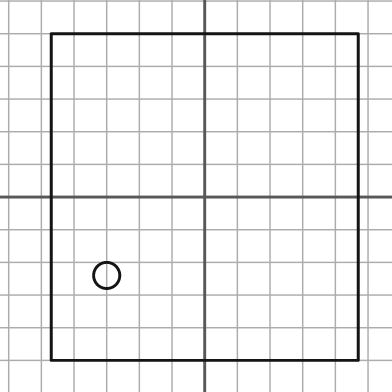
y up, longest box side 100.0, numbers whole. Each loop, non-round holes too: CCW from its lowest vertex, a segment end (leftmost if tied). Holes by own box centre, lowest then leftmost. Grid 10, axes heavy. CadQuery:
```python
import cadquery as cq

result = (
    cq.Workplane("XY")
    .moveTo(-47.0, -50.0)
    .lineTo(47.0, -50.0)
    .lineTo(47.0, 50.0)
    .lineTo(-47.0, 50.0)
    .close()
    .moveTo(-30.0, -24.0)
    .circle(4.0)
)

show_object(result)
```